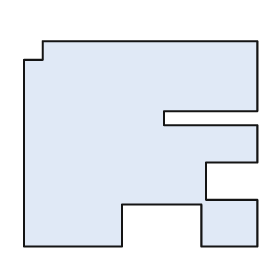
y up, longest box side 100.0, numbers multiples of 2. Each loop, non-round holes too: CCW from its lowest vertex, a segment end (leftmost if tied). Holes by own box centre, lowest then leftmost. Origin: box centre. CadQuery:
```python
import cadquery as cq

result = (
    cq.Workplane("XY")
    .moveTo(-50.0, -44.0)
    .lineTo(-8.0, -44.0)
    .lineTo(-8.0, -26.0)
    .lineTo(26.0, -26.0)
    .lineTo(26.0, -44.0)
    .lineTo(50.0, -44.0)
    .lineTo(50.0, -24.0)
    .lineTo(28.0, -24.0)
    .lineTo(28.0, -8.0)
    .lineTo(50.0, -8.0)
    .lineTo(50.0, 8.0)
    .lineTo(10.0, 8.0)
    .lineTo(10.0, 14.0)
    .lineTo(50.0, 14.0)
    .lineTo(50.0, 44.0)
    .lineTo(-42.0, 44.0)
    .lineTo(-42.0, 36.0)
    .lineTo(-50.0, 36.0)
    .close()
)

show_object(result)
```